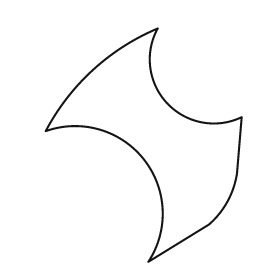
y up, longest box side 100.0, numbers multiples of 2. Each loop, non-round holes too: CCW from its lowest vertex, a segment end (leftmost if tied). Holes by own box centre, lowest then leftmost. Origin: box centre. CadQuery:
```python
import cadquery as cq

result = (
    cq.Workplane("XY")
    .moveTo(2.0, -50.0)
    .lineTo(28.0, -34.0)
    .threePointArc((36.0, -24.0), (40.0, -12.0))
    .lineTo(42.0, 12.0)
    .threePointArc((10.0, 18.0), (6.0, 50.0))
    .threePointArc((-22.0, 32.0), (-42.0, 6.0))
    .threePointArc((0.0, -6.0), (2.0, -50.0))
    .close()
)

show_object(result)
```